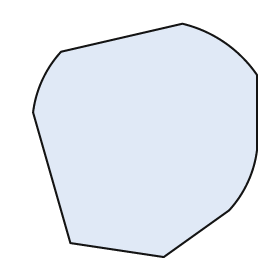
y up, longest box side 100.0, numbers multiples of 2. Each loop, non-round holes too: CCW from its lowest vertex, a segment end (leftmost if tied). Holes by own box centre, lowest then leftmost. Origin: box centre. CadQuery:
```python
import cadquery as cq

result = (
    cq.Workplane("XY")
    .moveTo(8.0, -50.0)
    .lineTo(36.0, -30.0)
    .threePointArc((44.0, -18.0), (48.0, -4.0))
    .lineTo(48.0, 28.0)
    .threePointArc((34.0, 42.0), (16.0, 50.0))
    .lineTo(-36.0, 38.0)
    .threePointArc((-44.0, 26.0), (-48.0, 12.0))
    .lineTo(-32.0, -44.0)
    .close()
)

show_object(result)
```